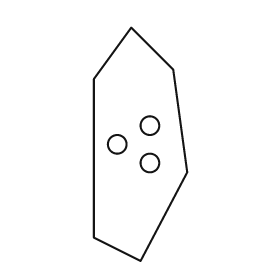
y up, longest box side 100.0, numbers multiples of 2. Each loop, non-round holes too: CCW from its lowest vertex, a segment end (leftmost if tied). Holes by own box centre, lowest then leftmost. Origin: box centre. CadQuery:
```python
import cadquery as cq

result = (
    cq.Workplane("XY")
    .moveTo(0.0, -50.0)
    .lineTo(20.0, -12.0)
    .lineTo(14.0, 32.0)
    .lineTo(-4.0, 50.0)
    .lineTo(-20.0, 28.0)
    .lineTo(-20.0, -40.0)
    .close()
    .moveTo(4.0, -8.0)
    .circle(4.0)
    .moveTo(-10.0, 0.0)
    .circle(4.0)
    .moveTo(4.0, 8.0)
    .circle(4.0)
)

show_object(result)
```